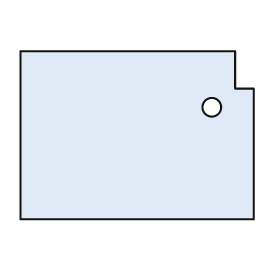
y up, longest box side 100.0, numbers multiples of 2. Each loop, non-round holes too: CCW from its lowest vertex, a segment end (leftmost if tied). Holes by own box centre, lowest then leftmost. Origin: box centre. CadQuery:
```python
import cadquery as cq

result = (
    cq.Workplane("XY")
    .moveTo(-50.0, -36.0)
    .lineTo(50.0, -36.0)
    .lineTo(50.0, 20.0)
    .lineTo(42.0, 20.0)
    .lineTo(42.0, 36.0)
    .lineTo(-50.0, 36.0)
    .close()
    .moveTo(32.0, 12.0)
    .circle(4.0)
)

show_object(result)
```